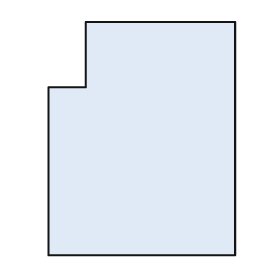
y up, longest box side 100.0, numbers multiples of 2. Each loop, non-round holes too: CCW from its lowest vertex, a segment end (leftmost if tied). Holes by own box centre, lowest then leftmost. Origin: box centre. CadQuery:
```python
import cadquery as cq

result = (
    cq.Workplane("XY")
    .moveTo(-40.0, -50.0)
    .lineTo(40.0, -50.0)
    .lineTo(40.0, 50.0)
    .lineTo(-24.0, 50.0)
    .lineTo(-24.0, 22.0)
    .lineTo(-40.0, 22.0)
    .close()
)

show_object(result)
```